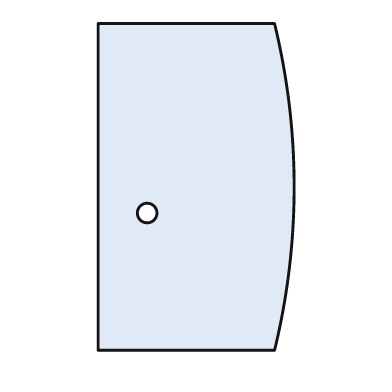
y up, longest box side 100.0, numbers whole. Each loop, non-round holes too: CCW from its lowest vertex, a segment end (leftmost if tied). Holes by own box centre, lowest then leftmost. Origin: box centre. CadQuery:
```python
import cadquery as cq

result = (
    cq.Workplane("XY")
    .moveTo(-30.0, -50.0)
    .lineTo(24.0, -50.0)
    .threePointArc((30.0, 0.0), (24.0, 50.0))
    .lineTo(-30.0, 50.0)
    .close()
    .moveTo(-15.0, -8.0)
    .circle(3.0)
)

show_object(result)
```